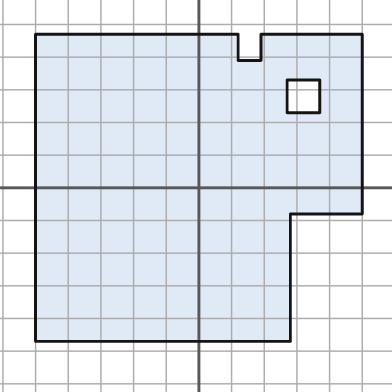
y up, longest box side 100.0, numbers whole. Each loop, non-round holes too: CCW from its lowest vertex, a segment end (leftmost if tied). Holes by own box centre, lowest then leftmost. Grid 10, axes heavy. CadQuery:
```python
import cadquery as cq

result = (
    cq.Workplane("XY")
    .moveTo(-50.0, -47.0)
    .lineTo(28.0, -47.0)
    .lineTo(28.0, -8.0)
    .lineTo(50.0, -8.0)
    .lineTo(50.0, 47.0)
    .lineTo(19.0, 47.0)
    .lineTo(19.0, 39.0)
    .lineTo(12.0, 39.0)
    .lineTo(12.0, 47.0)
    .lineTo(-50.0, 47.0)
    .close()
    .moveTo(27.0, 23.0)
    .lineTo(37.0, 23.0)
    .lineTo(37.0, 33.0)
    .lineTo(27.0, 33.0)
    .close()
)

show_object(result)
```